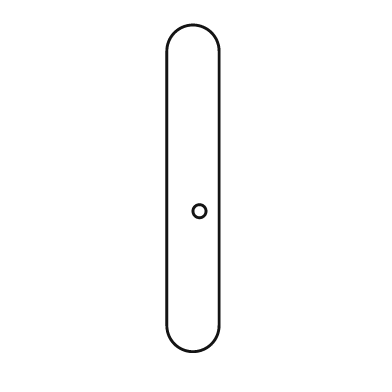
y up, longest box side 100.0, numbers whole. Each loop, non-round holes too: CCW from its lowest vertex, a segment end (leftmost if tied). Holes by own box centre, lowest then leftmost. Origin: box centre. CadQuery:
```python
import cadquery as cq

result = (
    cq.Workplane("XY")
    .moveTo(-8.0, -42.0)
    .threePointArc((0.0, -50.0), (8.0, -42.0))
    .lineTo(8.0, 42.0)
    .threePointArc((0.0, 50.0), (-8.0, 42.0))
    .close()
    .moveTo(2.0, -7.0)
    .circle(2.0)
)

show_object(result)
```